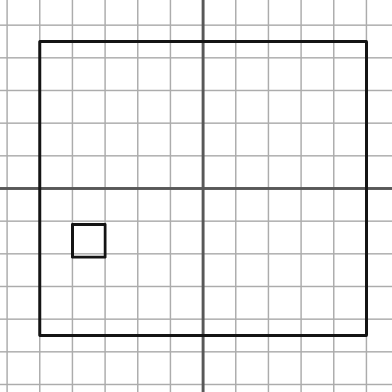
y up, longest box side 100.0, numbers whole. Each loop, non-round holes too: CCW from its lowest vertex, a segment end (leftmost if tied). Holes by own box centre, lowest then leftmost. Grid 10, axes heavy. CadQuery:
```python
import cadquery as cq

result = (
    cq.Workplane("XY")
    .moveTo(-50.0, -45.0)
    .lineTo(50.0, -45.0)
    .lineTo(50.0, 45.0)
    .lineTo(-50.0, 45.0)
    .close()
    .moveTo(-40.0, -21.0)
    .lineTo(-30.0, -21.0)
    .lineTo(-30.0, -11.0)
    .lineTo(-40.0, -11.0)
    .close()
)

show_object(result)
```